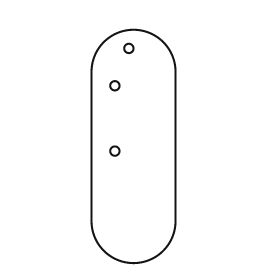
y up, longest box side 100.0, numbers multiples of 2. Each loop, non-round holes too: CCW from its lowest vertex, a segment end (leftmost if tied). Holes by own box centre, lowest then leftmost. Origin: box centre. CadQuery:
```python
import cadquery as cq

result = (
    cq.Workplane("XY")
    .moveTo(-18.0, -32.0)
    .threePointArc((0.0, -50.0), (18.0, -32.0))
    .lineTo(18.0, 32.0)
    .threePointArc((0.0, 50.0), (-18.0, 32.0))
    .close()
    .moveTo(-8.0, -2.0)
    .circle(2.0)
    .moveTo(-8.0, 26.0)
    .circle(2.0)
    .moveTo(-2.0, 42.0)
    .circle(2.0)
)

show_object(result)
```